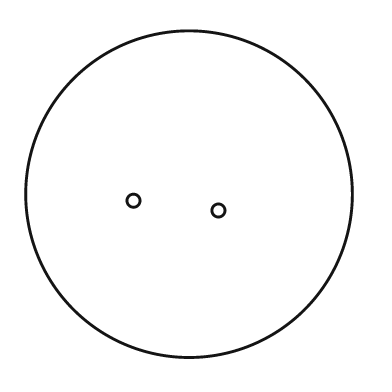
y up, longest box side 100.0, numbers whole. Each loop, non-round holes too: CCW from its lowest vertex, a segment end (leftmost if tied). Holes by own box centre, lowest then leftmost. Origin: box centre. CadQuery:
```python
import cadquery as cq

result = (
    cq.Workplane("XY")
    .moveTo(0.0, 0.0)
    .circle(50.0)
    .moveTo(9.0, -5.0)
    .circle(2.0)
    .moveTo(-17.0, -2.0)
    .circle(2.0)
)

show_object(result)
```